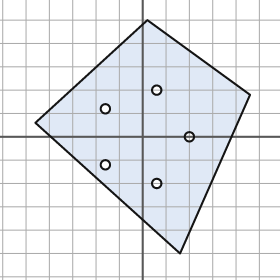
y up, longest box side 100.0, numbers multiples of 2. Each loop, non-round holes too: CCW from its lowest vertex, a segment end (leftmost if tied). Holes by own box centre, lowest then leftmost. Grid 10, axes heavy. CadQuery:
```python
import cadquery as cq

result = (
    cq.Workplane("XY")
    .moveTo(16.0, -50.0)
    .lineTo(46.0, 18.0)
    .lineTo(2.0, 50.0)
    .lineTo(-46.0, 6.0)
    .close()
    .moveTo(6.0, -20.0)
    .circle(2.0)
    .moveTo(-16.0, -12.0)
    .circle(2.0)
    .moveTo(20.0, 0.0)
    .circle(2.0)
    .moveTo(-16.0, 12.0)
    .circle(2.0)
    .moveTo(6.0, 20.0)
    .circle(2.0)
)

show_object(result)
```